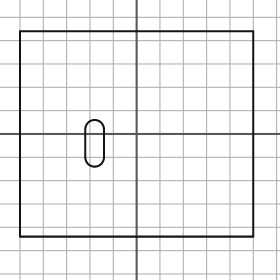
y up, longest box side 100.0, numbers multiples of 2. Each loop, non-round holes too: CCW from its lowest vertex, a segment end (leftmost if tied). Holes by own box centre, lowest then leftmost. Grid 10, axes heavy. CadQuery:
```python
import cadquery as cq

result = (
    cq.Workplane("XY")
    .moveTo(-50.0, -44.0)
    .lineTo(50.0, -44.0)
    .lineTo(50.0, 44.0)
    .lineTo(-50.0, 44.0)
    .close()
    .moveTo(-22.0, -10.0)
    .threePointArc((-18.0, -14.0), (-14.0, -10.0))
    .lineTo(-14.0, 2.0)
    .threePointArc((-18.0, 6.0), (-22.0, 2.0))
    .close()
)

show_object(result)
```